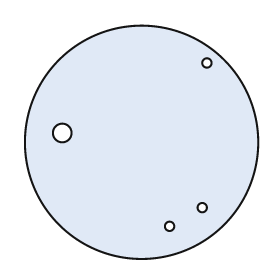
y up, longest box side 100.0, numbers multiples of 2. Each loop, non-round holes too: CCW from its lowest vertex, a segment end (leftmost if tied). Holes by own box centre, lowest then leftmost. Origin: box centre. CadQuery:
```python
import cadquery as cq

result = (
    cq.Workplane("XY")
    .moveTo(0.0, 0.0)
    .circle(50.0)
    .moveTo(12.0, -36.0)
    .circle(2.0)
    .moveTo(26.0, -28.0)
    .circle(2.0)
    .moveTo(-34.0, 4.0)
    .circle(4.0)
    .moveTo(28.0, 34.0)
    .circle(2.0)
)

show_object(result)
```